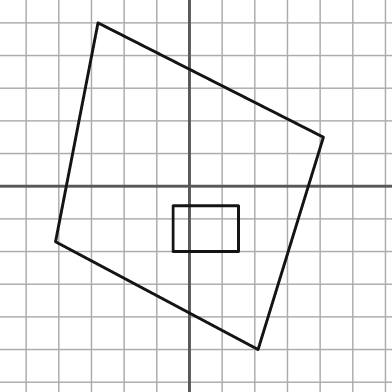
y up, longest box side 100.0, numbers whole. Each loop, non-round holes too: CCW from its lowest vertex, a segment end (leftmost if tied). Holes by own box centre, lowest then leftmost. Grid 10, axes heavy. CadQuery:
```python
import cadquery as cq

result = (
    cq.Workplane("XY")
    .moveTo(21.0, -50.0)
    .lineTo(41.0, 15.0)
    .lineTo(-28.0, 50.0)
    .lineTo(-41.0, -17.0)
    .close()
    .moveTo(-5.0, -20.0)
    .lineTo(15.0, -20.0)
    .lineTo(15.0, -6.0)
    .lineTo(-5.0, -6.0)
    .close()
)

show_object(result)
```